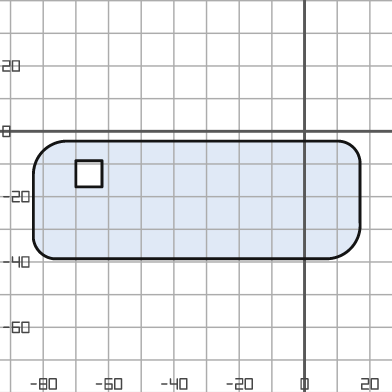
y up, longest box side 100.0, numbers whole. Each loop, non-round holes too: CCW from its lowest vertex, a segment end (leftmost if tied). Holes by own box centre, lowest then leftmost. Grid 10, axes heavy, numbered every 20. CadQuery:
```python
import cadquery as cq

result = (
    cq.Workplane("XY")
    .moveTo(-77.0, -39.0)
    .lineTo(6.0, -39.0)
    .threePointArc((14.0, -36.0), (17.0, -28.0))
    .lineTo(17.0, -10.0)
    .threePointArc((15.0, -5.0), (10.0, -3.0))
    .lineTo(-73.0, -3.0)
    .threePointArc((-80.0, -6.0), (-83.0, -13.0))
    .lineTo(-83.0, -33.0)
    .threePointArc((-81.0, -37.0), (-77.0, -39.0))
    .close()
    .moveTo(-70.0, -17.0)
    .lineTo(-62.0, -17.0)
    .lineTo(-62.0, -9.0)
    .lineTo(-70.0, -9.0)
    .close()
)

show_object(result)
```